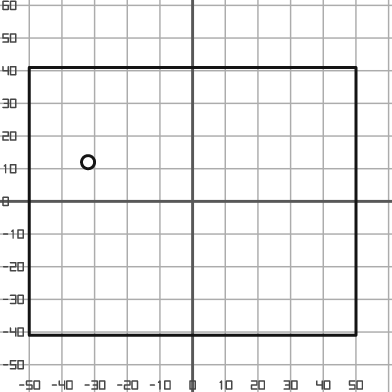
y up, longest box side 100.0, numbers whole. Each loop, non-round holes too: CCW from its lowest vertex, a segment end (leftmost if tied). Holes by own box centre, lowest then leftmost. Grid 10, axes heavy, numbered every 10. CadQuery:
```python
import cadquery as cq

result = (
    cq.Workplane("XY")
    .moveTo(-50.0, -41.0)
    .lineTo(50.0, -41.0)
    .lineTo(50.0, 41.0)
    .lineTo(-50.0, 41.0)
    .close()
    .moveTo(-32.0, 12.0)
    .circle(2.0)
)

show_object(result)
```